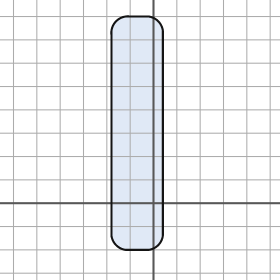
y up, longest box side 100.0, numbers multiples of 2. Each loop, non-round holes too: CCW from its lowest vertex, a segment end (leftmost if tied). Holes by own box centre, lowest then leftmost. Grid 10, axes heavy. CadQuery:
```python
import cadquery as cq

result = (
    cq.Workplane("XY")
    .moveTo(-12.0, -20.0)
    .lineTo(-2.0, -20.0)
    .threePointArc((2.0, -18.0), (4.0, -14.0))
    .lineTo(4.0, 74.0)
    .threePointArc((2.0, 78.0), (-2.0, 80.0))
    .lineTo(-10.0, 80.0)
    .threePointArc((-16.0, 78.0), (-18.0, 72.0))
    .lineTo(-18.0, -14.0)
    .threePointArc((-16.0, -18.0), (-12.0, -20.0))
    .close()
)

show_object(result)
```